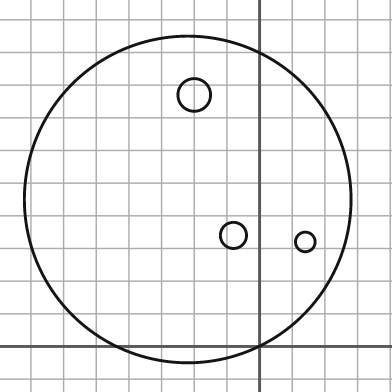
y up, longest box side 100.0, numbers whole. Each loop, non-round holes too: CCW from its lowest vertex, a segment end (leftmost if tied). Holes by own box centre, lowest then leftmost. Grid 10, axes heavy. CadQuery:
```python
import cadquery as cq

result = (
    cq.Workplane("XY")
    .moveTo(-22.0, 45.0)
    .circle(50.0)
    .moveTo(14.0, 32.0)
    .circle(3.0)
    .moveTo(-8.0, 34.0)
    .circle(4.0)
    .moveTo(-20.0, 77.0)
    .circle(5.0)
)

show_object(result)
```